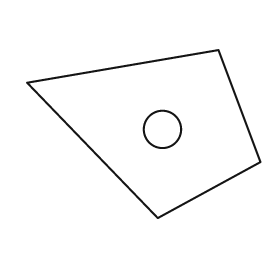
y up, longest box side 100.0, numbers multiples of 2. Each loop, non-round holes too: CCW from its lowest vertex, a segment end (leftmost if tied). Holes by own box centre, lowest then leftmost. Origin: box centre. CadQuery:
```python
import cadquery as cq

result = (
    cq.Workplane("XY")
    .moveTo(6.0, -36.0)
    .lineTo(50.0, -12.0)
    .lineTo(32.0, 36.0)
    .lineTo(-50.0, 22.0)
    .close()
    .moveTo(8.0, 2.0)
    .circle(8.0)
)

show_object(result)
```